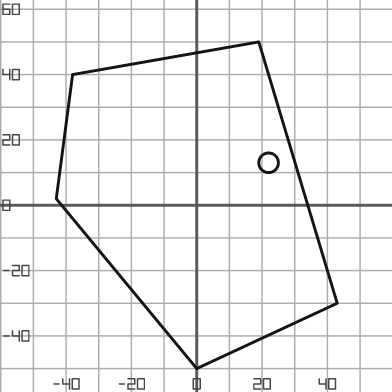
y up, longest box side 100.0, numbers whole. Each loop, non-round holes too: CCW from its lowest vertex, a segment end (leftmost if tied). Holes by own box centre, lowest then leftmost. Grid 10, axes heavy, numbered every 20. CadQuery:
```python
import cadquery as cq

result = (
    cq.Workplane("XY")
    .moveTo(0.0, -50.0)
    .lineTo(43.0, -30.0)
    .lineTo(19.0, 50.0)
    .lineTo(-38.0, 40.0)
    .lineTo(-43.0, 2.0)
    .close()
    .moveTo(22.0, 13.0)
    .circle(3.0)
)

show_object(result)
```